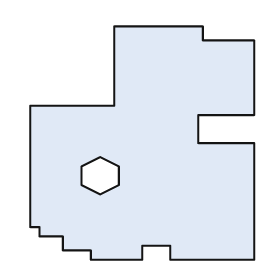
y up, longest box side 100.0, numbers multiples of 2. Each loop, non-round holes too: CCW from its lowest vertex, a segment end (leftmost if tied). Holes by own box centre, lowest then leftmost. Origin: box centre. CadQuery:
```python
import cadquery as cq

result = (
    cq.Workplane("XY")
    .moveTo(-22.0, -50.0)
    .lineTo(0.0, -50.0)
    .lineTo(0.0, -44.0)
    .lineTo(12.0, -44.0)
    .lineTo(12.0, -50.0)
    .lineTo(48.0, -50.0)
    .lineTo(48.0, 0.0)
    .lineTo(24.0, 0.0)
    .lineTo(24.0, 12.0)
    .lineTo(48.0, 12.0)
    .lineTo(48.0, 44.0)
    .lineTo(26.0, 44.0)
    .lineTo(26.0, 50.0)
    .lineTo(-12.0, 50.0)
    .lineTo(-12.0, 16.0)
    .lineTo(-48.0, 16.0)
    .lineTo(-48.0, -36.0)
    .lineTo(-44.0, -36.0)
    .lineTo(-44.0, -40.0)
    .lineTo(-34.0, -40.0)
    .lineTo(-34.0, -46.0)
    .lineTo(-22.0, -46.0)
    .close()
    .moveTo(-18.0, -22.0)
    .lineTo(-10.0, -18.0)
    .lineTo(-10.0, -10.0)
    .lineTo(-18.0, -6.0)
    .lineTo(-26.0, -10.0)
    .lineTo(-26.0, -18.0)
    .close()
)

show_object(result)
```